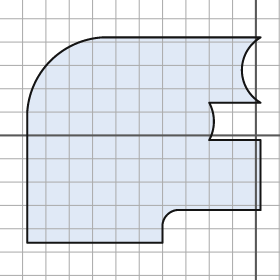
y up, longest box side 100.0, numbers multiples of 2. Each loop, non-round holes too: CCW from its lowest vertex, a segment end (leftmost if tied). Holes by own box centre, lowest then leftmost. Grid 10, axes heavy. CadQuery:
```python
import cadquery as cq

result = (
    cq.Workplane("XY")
    .moveTo(-98.0, -46.0)
    .lineTo(-40.0, -46.0)
    .lineTo(-40.0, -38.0)
    .threePointArc((-38.0, -34.0), (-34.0, -32.0))
    .lineTo(2.0, -32.0)
    .lineTo(2.0, -2.0)
    .lineTo(-20.0, -2.0)
    .threePointArc((-18.0, 6.0), (-20.0, 14.0))
    .lineTo(2.0, 14.0)
    .threePointArc((-6.0, 28.0), (2.0, 42.0))
    .lineTo(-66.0, 42.0)
    .threePointArc((-88.0, 32.0), (-98.0, 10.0))
    .close()
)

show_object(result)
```